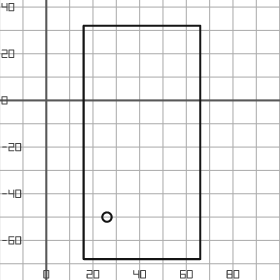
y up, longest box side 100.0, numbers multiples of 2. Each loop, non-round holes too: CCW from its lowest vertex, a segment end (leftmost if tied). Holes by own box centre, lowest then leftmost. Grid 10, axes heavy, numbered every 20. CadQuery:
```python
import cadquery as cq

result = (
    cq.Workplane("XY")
    .moveTo(16.0, -68.0)
    .lineTo(66.0, -68.0)
    .lineTo(66.0, 32.0)
    .lineTo(16.0, 32.0)
    .close()
    .moveTo(26.0, -50.0)
    .circle(2.0)
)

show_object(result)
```